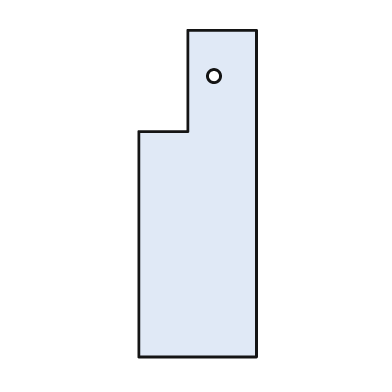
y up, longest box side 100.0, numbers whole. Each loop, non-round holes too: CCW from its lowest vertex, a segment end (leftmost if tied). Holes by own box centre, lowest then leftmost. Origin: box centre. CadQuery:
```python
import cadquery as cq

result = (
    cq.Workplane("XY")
    .moveTo(-18.0, -50.0)
    .lineTo(18.0, -50.0)
    .lineTo(18.0, 50.0)
    .lineTo(-3.0, 50.0)
    .lineTo(-3.0, 19.0)
    .lineTo(-18.0, 19.0)
    .close()
    .moveTo(5.0, 36.0)
    .circle(2.0)
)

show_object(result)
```